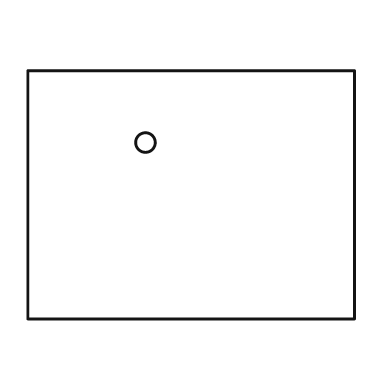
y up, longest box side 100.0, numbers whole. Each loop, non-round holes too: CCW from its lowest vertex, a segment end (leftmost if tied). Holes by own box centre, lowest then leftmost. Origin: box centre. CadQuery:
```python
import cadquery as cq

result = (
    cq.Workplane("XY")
    .moveTo(-50.0, -38.0)
    .lineTo(50.0, -38.0)
    .lineTo(50.0, 38.0)
    .lineTo(-50.0, 38.0)
    .close()
    .moveTo(-14.0, 16.0)
    .circle(3.0)
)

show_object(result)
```